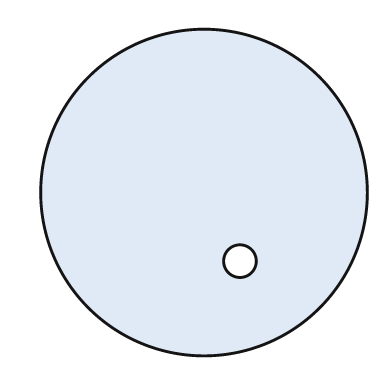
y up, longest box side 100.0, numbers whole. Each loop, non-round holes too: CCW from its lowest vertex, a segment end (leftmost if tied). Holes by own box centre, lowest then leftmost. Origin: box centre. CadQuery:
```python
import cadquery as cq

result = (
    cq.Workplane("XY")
    .moveTo(0.0, 0.0)
    .circle(50.0)
    .moveTo(11.0, -21.0)
    .circle(5.0)
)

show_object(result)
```